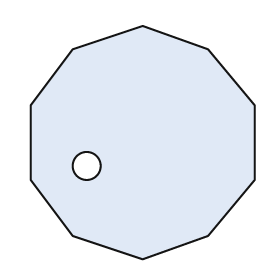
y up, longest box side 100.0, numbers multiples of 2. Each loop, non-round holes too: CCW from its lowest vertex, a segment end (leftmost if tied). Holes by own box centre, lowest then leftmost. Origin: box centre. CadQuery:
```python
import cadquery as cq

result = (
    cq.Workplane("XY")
    .moveTo(0.0, -50.0)
    .lineTo(28.0, -40.0)
    .lineTo(48.0, -16.0)
    .lineTo(48.0, 16.0)
    .lineTo(28.0, 40.0)
    .lineTo(0.0, 50.0)
    .lineTo(-30.0, 40.0)
    .lineTo(-48.0, 16.0)
    .lineTo(-48.0, -16.0)
    .lineTo(-30.0, -40.0)
    .close()
    .moveTo(-24.0, -10.0)
    .circle(6.0)
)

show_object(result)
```